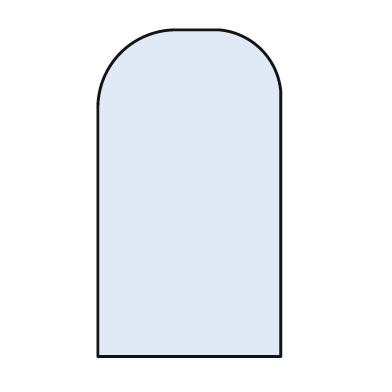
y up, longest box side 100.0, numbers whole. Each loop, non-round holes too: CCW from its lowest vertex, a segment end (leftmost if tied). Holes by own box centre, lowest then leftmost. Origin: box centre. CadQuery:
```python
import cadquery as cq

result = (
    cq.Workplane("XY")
    .moveTo(-28.0, -50.0)
    .lineTo(28.0, -50.0)
    .lineTo(28.0, 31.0)
    .threePointArc((22.0, 44.0), (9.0, 50.0))
    .lineTo(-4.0, 50.0)
    .threePointArc((-21.0, 43.0), (-28.0, 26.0))
    .close()
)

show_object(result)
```